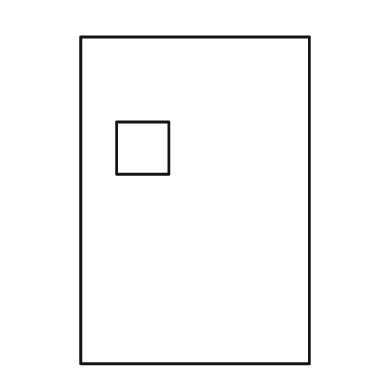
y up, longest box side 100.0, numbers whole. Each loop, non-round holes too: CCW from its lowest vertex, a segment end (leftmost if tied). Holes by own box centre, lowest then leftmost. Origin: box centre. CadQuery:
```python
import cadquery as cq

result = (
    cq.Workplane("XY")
    .moveTo(-35.0, -50.0)
    .lineTo(35.0, -50.0)
    .lineTo(35.0, 50.0)
    .lineTo(-35.0, 50.0)
    .close()
    .moveTo(-24.0, 8.0)
    .lineTo(-8.0, 8.0)
    .lineTo(-8.0, 24.0)
    .lineTo(-24.0, 24.0)
    .close()
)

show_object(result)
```